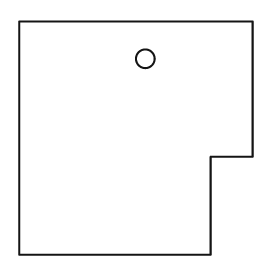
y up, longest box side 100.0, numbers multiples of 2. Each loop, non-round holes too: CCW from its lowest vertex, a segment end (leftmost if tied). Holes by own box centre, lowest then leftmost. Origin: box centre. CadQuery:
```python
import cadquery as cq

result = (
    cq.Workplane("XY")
    .moveTo(-50.0, -50.0)
    .lineTo(32.0, -50.0)
    .lineTo(32.0, -8.0)
    .lineTo(50.0, -8.0)
    .lineTo(50.0, 50.0)
    .lineTo(-50.0, 50.0)
    .close()
    .moveTo(4.0, 34.0)
    .circle(4.0)
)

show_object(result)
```